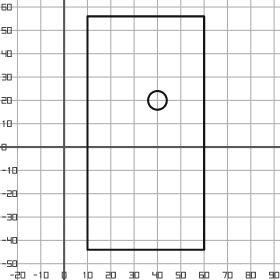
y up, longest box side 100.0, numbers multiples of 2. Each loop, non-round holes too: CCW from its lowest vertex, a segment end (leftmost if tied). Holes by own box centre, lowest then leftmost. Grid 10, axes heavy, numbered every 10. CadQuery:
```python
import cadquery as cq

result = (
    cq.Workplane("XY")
    .moveTo(10.0, -44.0)
    .lineTo(60.0, -44.0)
    .lineTo(60.0, 56.0)
    .lineTo(10.0, 56.0)
    .close()
    .moveTo(40.0, 20.0)
    .circle(4.0)
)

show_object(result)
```